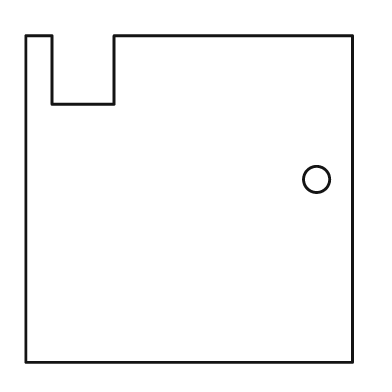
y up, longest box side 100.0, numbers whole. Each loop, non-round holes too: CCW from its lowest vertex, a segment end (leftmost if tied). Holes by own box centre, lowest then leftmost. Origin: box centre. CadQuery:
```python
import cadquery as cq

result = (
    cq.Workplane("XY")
    .moveTo(-50.0, -50.0)
    .lineTo(50.0, -50.0)
    .lineTo(50.0, 50.0)
    .lineTo(-23.0, 50.0)
    .lineTo(-23.0, 29.0)
    .lineTo(-42.0, 29.0)
    .lineTo(-42.0, 50.0)
    .lineTo(-50.0, 50.0)
    .close()
    .moveTo(39.0, 6.0)
    .circle(4.0)
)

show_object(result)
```